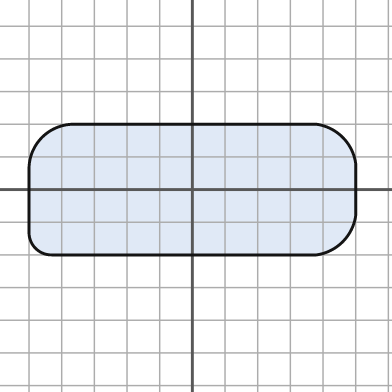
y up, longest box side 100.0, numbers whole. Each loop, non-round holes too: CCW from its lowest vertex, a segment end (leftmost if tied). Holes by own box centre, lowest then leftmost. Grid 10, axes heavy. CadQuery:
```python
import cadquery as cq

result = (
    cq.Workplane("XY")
    .moveTo(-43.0, -20.0)
    .lineTo(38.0, -20.0)
    .threePointArc((46.0, -16.0), (50.0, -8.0))
    .lineTo(50.0, 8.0)
    .threePointArc((46.0, 16.0), (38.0, 20.0))
    .lineTo(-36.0, 20.0)
    .threePointArc((-46.0, 16.0), (-50.0, 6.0))
    .lineTo(-50.0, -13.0)
    .threePointArc((-48.0, -18.0), (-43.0, -20.0))
    .close()
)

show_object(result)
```